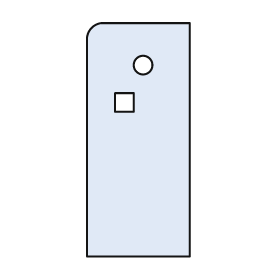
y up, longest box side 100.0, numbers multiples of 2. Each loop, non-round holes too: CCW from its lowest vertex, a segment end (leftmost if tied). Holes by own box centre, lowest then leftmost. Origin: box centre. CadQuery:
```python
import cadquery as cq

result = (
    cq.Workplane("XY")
    .moveTo(-22.0, -50.0)
    .lineTo(22.0, -50.0)
    .lineTo(22.0, 50.0)
    .lineTo(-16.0, 50.0)
    .threePointArc((-20.0, 48.0), (-22.0, 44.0))
    .close()
    .moveTo(-10.0, 12.0)
    .lineTo(-2.0, 12.0)
    .lineTo(-2.0, 20.0)
    .lineTo(-10.0, 20.0)
    .close()
    .moveTo(2.0, 32.0)
    .circle(4.0)
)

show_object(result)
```